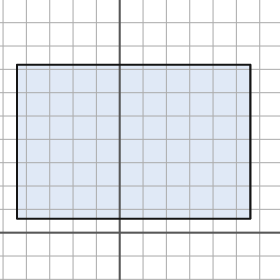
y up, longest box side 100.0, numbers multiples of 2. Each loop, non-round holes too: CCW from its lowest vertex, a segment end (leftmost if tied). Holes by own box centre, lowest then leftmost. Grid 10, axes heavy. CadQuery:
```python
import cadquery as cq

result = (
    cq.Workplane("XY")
    .moveTo(-44.0, 6.0)
    .lineTo(56.0, 6.0)
    .lineTo(56.0, 72.0)
    .lineTo(-44.0, 72.0)
    .close()
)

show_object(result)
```